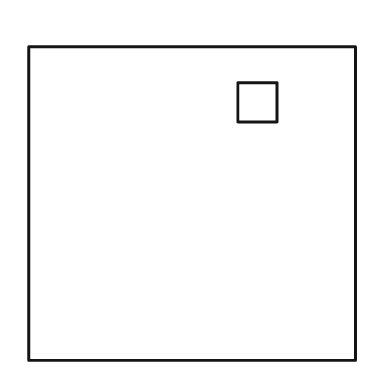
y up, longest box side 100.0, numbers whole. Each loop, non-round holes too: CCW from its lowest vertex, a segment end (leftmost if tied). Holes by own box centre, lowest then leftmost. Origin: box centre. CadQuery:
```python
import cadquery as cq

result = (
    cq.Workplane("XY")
    .moveTo(-50.0, -48.0)
    .lineTo(50.0, -48.0)
    .lineTo(50.0, 48.0)
    .lineTo(-50.0, 48.0)
    .close()
    .moveTo(14.0, 25.0)
    .lineTo(26.0, 25.0)
    .lineTo(26.0, 37.0)
    .lineTo(14.0, 37.0)
    .close()
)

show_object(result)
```